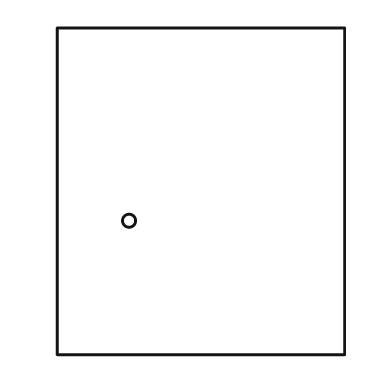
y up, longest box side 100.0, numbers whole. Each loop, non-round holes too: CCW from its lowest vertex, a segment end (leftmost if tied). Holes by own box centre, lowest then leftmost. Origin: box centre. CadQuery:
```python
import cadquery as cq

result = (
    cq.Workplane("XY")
    .moveTo(-44.0, -50.0)
    .lineTo(44.0, -50.0)
    .lineTo(44.0, 50.0)
    .lineTo(-44.0, 50.0)
    .close()
    .moveTo(-22.0, -9.0)
    .circle(2.0)
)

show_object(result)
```